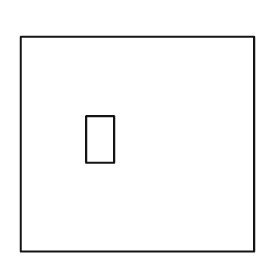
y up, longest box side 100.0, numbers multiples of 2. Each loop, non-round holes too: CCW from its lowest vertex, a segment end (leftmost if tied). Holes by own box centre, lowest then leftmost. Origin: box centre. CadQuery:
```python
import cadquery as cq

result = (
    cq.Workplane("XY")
    .moveTo(-50.0, -46.0)
    .lineTo(50.0, -46.0)
    .lineTo(50.0, 46.0)
    .lineTo(-50.0, 46.0)
    .close()
    .moveTo(-22.0, -8.0)
    .lineTo(-10.0, -8.0)
    .lineTo(-10.0, 12.0)
    .lineTo(-22.0, 12.0)
    .close()
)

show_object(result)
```